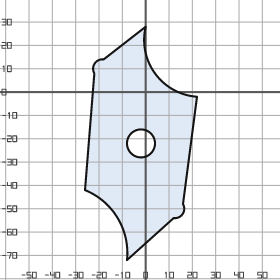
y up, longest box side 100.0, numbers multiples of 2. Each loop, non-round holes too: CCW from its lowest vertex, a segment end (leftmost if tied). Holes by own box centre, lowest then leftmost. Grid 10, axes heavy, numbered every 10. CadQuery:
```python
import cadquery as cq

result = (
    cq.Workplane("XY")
    .moveTo(-8.0, -72.0)
    .lineTo(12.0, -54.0)
    .threePointArc((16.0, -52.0), (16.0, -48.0))
    .lineTo(22.0, -2.0)
    .threePointArc((4.0, 8.0), (0.0, 28.0))
    .lineTo(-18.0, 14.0)
    .threePointArc((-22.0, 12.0), (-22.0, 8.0))
    .lineTo(-26.0, -42.0)
    .threePointArc((-12.0, -54.0), (-8.0, -72.0))
    .close()
    .moveTo(-2.0, -22.0)
    .circle(6.0)
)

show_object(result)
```